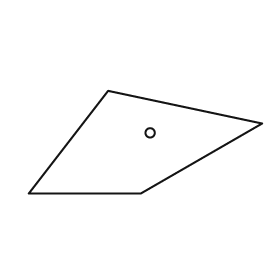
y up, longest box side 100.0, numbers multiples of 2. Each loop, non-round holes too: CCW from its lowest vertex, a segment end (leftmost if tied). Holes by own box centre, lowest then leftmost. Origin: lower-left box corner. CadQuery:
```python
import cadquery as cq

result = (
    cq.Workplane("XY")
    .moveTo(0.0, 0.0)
    .lineTo(48.0, 0.0)
    .lineTo(100.0, 30.0)
    .lineTo(34.0, 44.0)
    .close()
    .moveTo(52.0, 26.0)
    .circle(2.0)
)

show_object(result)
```